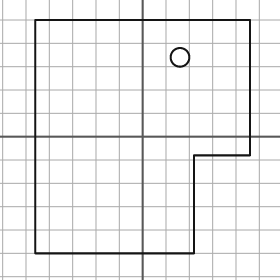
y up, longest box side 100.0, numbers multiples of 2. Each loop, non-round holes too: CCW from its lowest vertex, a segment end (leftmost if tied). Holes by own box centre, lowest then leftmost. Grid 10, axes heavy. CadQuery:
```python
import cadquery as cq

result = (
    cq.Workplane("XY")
    .moveTo(-46.0, -50.0)
    .lineTo(22.0, -50.0)
    .lineTo(22.0, -8.0)
    .lineTo(46.0, -8.0)
    .lineTo(46.0, 50.0)
    .lineTo(-46.0, 50.0)
    .close()
    .moveTo(16.0, 34.0)
    .circle(4.0)
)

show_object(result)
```